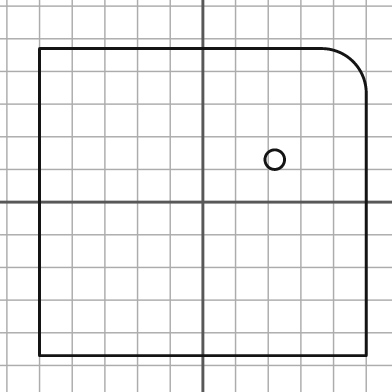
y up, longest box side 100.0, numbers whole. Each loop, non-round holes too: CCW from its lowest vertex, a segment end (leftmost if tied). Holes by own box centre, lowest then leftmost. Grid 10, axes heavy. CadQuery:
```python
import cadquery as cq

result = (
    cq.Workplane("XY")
    .moveTo(-50.0, -47.0)
    .lineTo(50.0, -47.0)
    .lineTo(50.0, 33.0)
    .threePointArc((46.0, 43.0), (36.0, 47.0))
    .lineTo(-50.0, 47.0)
    .close()
    .moveTo(22.0, 13.0)
    .circle(3.0)
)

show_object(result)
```